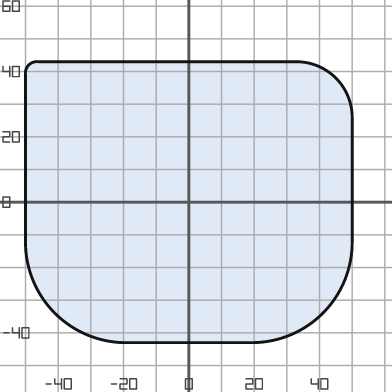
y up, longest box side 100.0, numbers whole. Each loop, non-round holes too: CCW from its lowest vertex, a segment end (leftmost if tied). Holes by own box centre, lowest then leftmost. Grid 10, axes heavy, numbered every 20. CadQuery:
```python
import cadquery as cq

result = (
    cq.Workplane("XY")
    .moveTo(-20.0, -43.0)
    .lineTo(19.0, -43.0)
    .threePointArc((41.0, -34.0), (50.0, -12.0))
    .lineTo(50.0, 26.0)
    .threePointArc((45.0, 38.0), (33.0, 43.0))
    .lineTo(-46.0, 43.0)
    .threePointArc((-49.0, 42.0), (-50.0, 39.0))
    .lineTo(-50.0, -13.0)
    .threePointArc((-41.0, -34.0), (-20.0, -43.0))
    .close()
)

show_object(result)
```